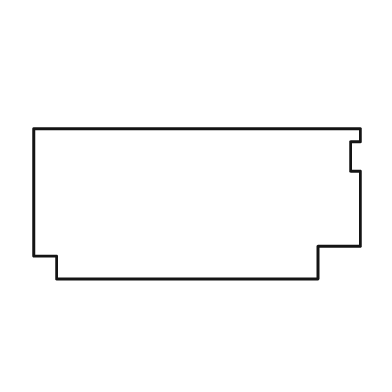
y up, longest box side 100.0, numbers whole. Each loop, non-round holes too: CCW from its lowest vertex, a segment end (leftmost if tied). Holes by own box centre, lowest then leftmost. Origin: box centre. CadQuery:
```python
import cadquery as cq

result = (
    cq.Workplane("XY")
    .moveTo(-43.0, -23.0)
    .lineTo(37.0, -23.0)
    .lineTo(37.0, -13.0)
    .lineTo(50.0, -13.0)
    .lineTo(50.0, 10.0)
    .lineTo(47.0, 10.0)
    .lineTo(47.0, 19.0)
    .lineTo(50.0, 19.0)
    .lineTo(50.0, 23.0)
    .lineTo(-50.0, 23.0)
    .lineTo(-50.0, -16.0)
    .lineTo(-43.0, -16.0)
    .close()
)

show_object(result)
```